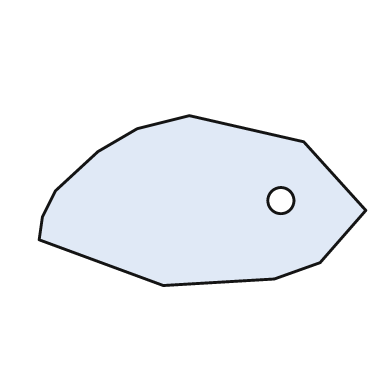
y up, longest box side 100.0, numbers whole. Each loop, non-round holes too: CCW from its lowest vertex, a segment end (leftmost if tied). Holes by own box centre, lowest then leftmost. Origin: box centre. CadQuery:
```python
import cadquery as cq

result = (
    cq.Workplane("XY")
    .moveTo(-12.0, -26.0)
    .lineTo(22.0, -24.0)
    .lineTo(36.0, -19.0)
    .lineTo(50.0, -3.0)
    .lineTo(31.0, 18.0)
    .lineTo(-4.0, 26.0)
    .lineTo(-20.0, 22.0)
    .lineTo(-32.0, 15.0)
    .lineTo(-45.0, 3.0)
    .lineTo(-49.0, -5.0)
    .lineTo(-50.0, -12.0)
    .close()
    .moveTo(24.0, 0.0)
    .circle(4.0)
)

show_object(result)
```